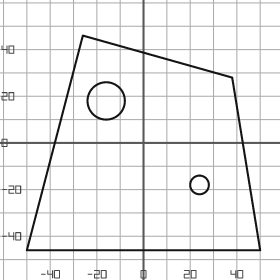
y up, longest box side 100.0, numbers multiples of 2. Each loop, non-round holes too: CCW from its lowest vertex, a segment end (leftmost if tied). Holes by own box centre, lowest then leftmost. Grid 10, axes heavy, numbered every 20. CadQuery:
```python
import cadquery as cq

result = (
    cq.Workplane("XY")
    .moveTo(-50.0, -46.0)
    .lineTo(50.0, -46.0)
    .lineTo(38.0, 28.0)
    .lineTo(-26.0, 46.0)
    .close()
    .moveTo(24.0, -18.0)
    .circle(4.0)
    .moveTo(-16.0, 18.0)
    .circle(8.0)
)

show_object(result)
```